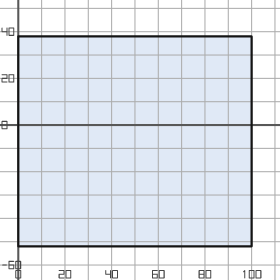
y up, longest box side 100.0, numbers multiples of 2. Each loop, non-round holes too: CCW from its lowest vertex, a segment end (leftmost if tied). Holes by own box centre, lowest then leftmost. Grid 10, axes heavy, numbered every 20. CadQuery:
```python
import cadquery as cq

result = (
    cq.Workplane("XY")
    .moveTo(0.0, -52.0)
    .lineTo(100.0, -52.0)
    .lineTo(100.0, 38.0)
    .lineTo(0.0, 38.0)
    .close()
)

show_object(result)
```